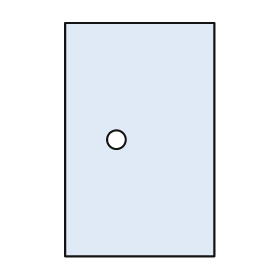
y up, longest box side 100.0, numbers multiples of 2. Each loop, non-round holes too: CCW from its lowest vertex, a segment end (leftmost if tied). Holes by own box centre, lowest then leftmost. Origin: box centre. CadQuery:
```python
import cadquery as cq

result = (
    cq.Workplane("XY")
    .moveTo(-32.0, -50.0)
    .lineTo(32.0, -50.0)
    .lineTo(32.0, 50.0)
    .lineTo(-32.0, 50.0)
    .close()
    .moveTo(-10.0, 0.0)
    .circle(4.0)
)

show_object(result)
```